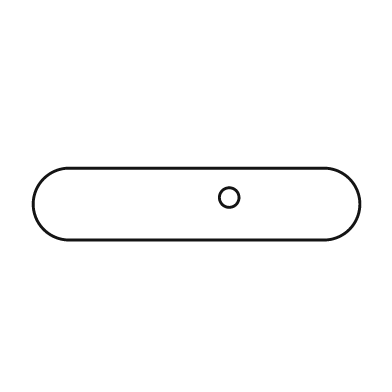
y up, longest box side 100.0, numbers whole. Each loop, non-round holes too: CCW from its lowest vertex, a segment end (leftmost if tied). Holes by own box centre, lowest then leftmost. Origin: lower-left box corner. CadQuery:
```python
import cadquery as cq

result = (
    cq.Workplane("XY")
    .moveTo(11.0, 0.0)
    .lineTo(89.0, 0.0)
    .threePointArc((100.0, 11.0), (89.0, 22.0))
    .lineTo(11.0, 22.0)
    .threePointArc((0.0, 11.0), (11.0, 0.0))
    .close()
    .moveTo(60.0, 13.0)
    .circle(3.0)
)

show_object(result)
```